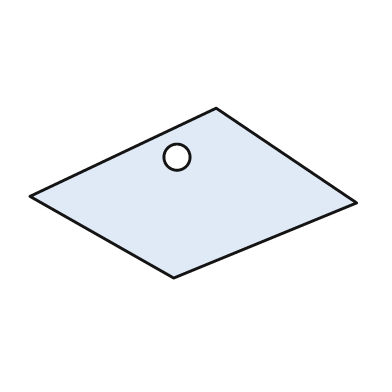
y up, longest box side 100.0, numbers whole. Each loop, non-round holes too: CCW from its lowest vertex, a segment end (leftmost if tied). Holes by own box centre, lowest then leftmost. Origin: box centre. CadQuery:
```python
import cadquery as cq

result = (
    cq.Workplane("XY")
    .moveTo(-6.0, -26.0)
    .lineTo(50.0, -3.0)
    .lineTo(7.0, 26.0)
    .lineTo(-50.0, -1.0)
    .close()
    .moveTo(-5.0, 11.0)
    .circle(4.0)
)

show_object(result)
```